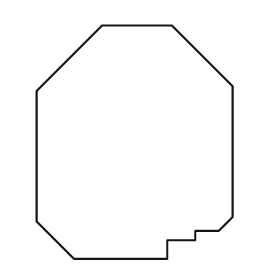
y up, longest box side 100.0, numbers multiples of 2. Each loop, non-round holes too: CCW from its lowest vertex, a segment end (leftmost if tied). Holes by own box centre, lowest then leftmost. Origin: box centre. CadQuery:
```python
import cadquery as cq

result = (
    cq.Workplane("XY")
    .moveTo(-26.0, -50.0)
    .lineTo(14.0, -50.0)
    .lineTo(14.0, -42.0)
    .lineTo(26.0, -42.0)
    .lineTo(26.0, -38.0)
    .lineTo(36.0, -38.0)
    .lineTo(42.0, -32.0)
    .lineTo(42.0, 24.0)
    .lineTo(16.0, 50.0)
    .lineTo(-14.0, 50.0)
    .lineTo(-42.0, 22.0)
    .lineTo(-42.0, -34.0)
    .close()
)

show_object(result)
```